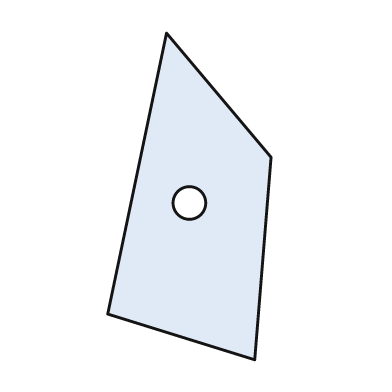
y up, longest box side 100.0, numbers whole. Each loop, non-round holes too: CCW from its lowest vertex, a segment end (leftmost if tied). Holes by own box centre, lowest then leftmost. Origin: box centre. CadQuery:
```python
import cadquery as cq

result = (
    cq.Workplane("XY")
    .moveTo(20.0, -50.0)
    .lineTo(25.0, 12.0)
    .lineTo(-7.0, 50.0)
    .lineTo(-25.0, -36.0)
    .close()
    .moveTo(0.0, -2.0)
    .circle(5.0)
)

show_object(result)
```